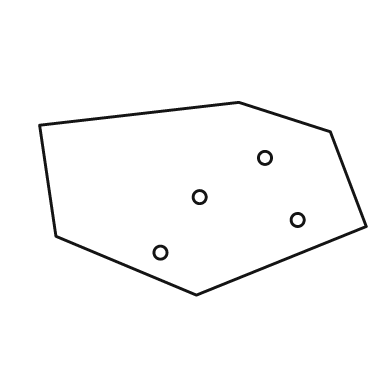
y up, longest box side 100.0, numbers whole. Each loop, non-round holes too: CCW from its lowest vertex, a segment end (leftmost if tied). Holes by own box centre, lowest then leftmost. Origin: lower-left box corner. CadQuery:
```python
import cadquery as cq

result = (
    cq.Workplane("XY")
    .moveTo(48.0, 0.0)
    .lineTo(100.0, 21.0)
    .lineTo(89.0, 50.0)
    .lineTo(61.0, 59.0)
    .lineTo(0.0, 52.0)
    .lineTo(5.0, 18.0)
    .close()
    .moveTo(37.0, 13.0)
    .circle(2.0)
    .moveTo(79.0, 23.0)
    .circle(2.0)
    .moveTo(49.0, 30.0)
    .circle(2.0)
    .moveTo(69.0, 42.0)
    .circle(2.0)
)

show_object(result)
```